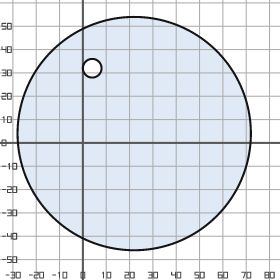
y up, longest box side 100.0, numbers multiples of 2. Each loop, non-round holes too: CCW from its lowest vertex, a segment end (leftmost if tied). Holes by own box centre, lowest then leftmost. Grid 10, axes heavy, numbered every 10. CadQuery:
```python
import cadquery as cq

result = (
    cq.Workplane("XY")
    .moveTo(22.0, 4.0)
    .circle(50.0)
    .moveTo(4.0, 32.0)
    .circle(4.0)
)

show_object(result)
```